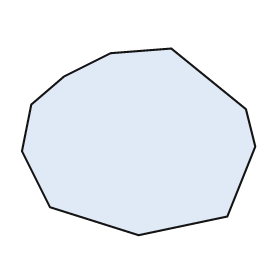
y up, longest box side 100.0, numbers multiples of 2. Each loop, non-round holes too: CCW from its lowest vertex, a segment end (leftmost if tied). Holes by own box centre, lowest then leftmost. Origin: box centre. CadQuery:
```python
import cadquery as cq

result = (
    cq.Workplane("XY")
    .moveTo(0.0, -40.0)
    .lineTo(38.0, -32.0)
    .lineTo(50.0, -2.0)
    .lineTo(46.0, 14.0)
    .lineTo(14.0, 40.0)
    .lineTo(-12.0, 38.0)
    .lineTo(-32.0, 28.0)
    .lineTo(-46.0, 16.0)
    .lineTo(-50.0, -4.0)
    .lineTo(-38.0, -28.0)
    .close()
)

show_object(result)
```